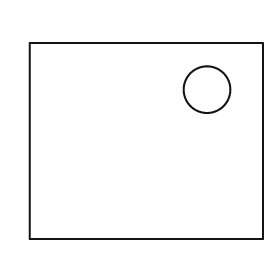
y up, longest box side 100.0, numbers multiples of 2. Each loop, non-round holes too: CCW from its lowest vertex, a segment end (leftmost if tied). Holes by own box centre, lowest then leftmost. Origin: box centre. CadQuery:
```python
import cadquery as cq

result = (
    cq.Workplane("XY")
    .moveTo(-50.0, -42.0)
    .lineTo(50.0, -42.0)
    .lineTo(50.0, 42.0)
    .lineTo(-50.0, 42.0)
    .close()
    .moveTo(26.0, 22.0)
    .circle(10.0)
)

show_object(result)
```